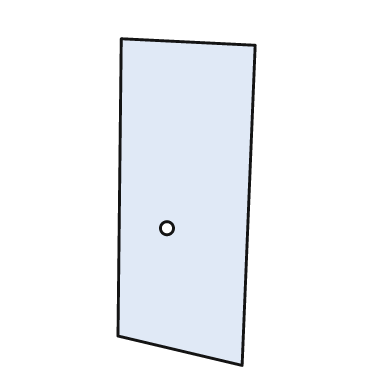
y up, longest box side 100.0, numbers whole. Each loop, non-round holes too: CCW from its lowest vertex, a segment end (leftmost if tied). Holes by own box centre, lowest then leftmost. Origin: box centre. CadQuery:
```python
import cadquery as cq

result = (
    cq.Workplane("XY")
    .moveTo(17.0, -50.0)
    .lineTo(21.0, 48.0)
    .lineTo(-20.0, 50.0)
    .lineTo(-21.0, -41.0)
    .close()
    .moveTo(-6.0, -8.0)
    .circle(2.0)
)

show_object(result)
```